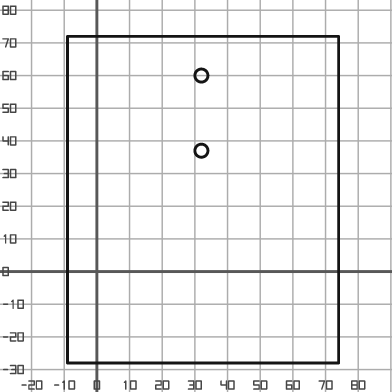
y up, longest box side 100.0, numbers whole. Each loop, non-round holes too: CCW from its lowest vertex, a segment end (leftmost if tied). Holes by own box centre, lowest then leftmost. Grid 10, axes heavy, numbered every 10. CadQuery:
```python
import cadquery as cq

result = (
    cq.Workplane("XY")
    .moveTo(-9.0, -28.0)
    .lineTo(74.0, -28.0)
    .lineTo(74.0, 72.0)
    .lineTo(-9.0, 72.0)
    .close()
    .moveTo(32.0, 37.0)
    .circle(2.0)
    .moveTo(32.0, 60.0)
    .circle(2.0)
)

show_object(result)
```